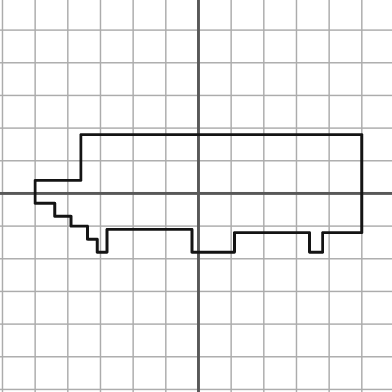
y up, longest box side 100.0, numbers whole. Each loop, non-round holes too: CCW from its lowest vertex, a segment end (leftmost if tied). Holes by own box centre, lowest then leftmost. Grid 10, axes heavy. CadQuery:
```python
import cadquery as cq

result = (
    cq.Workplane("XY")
    .moveTo(-31.0, -18.0)
    .lineTo(-28.0, -18.0)
    .lineTo(-28.0, -11.0)
    .lineTo(-2.0, -11.0)
    .lineTo(-2.0, -18.0)
    .lineTo(11.0, -18.0)
    .lineTo(11.0, -12.0)
    .lineTo(34.0, -12.0)
    .lineTo(34.0, -18.0)
    .lineTo(38.0, -18.0)
    .lineTo(38.0, -12.0)
    .lineTo(50.0, -12.0)
    .lineTo(50.0, 18.0)
    .lineTo(-36.0, 18.0)
    .lineTo(-36.0, 4.0)
    .lineTo(-50.0, 4.0)
    .lineTo(-50.0, -3.0)
    .lineTo(-44.0, -3.0)
    .lineTo(-44.0, -7.0)
    .lineTo(-39.0, -7.0)
    .lineTo(-39.0, -10.0)
    .lineTo(-34.0, -10.0)
    .lineTo(-34.0, -14.0)
    .lineTo(-31.0, -14.0)
    .close()
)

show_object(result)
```